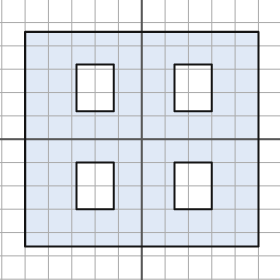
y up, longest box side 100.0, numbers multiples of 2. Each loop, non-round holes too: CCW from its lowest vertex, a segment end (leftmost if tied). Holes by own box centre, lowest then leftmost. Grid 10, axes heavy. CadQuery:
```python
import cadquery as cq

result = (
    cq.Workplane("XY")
    .moveTo(-50.0, -46.0)
    .lineTo(50.0, -46.0)
    .lineTo(50.0, 46.0)
    .lineTo(-50.0, 46.0)
    .close()
    .moveTo(-28.0, -30.0)
    .lineTo(-12.0, -30.0)
    .lineTo(-12.0, -10.0)
    .lineTo(-28.0, -10.0)
    .close()
    .moveTo(14.0, -30.0)
    .lineTo(30.0, -30.0)
    .lineTo(30.0, -10.0)
    .lineTo(14.0, -10.0)
    .close()
    .moveTo(-28.0, 12.0)
    .lineTo(-12.0, 12.0)
    .lineTo(-12.0, 32.0)
    .lineTo(-28.0, 32.0)
    .close()
    .moveTo(14.0, 12.0)
    .lineTo(30.0, 12.0)
    .lineTo(30.0, 32.0)
    .lineTo(14.0, 32.0)
    .close()
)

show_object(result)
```